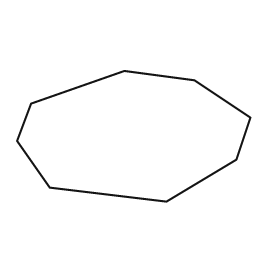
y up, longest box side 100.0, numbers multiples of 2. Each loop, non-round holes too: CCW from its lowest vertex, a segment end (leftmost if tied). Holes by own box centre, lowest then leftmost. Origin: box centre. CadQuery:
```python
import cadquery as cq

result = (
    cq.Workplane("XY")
    .moveTo(14.0, -28.0)
    .lineTo(44.0, -10.0)
    .lineTo(50.0, 8.0)
    .lineTo(26.0, 24.0)
    .lineTo(-4.0, 28.0)
    .lineTo(-44.0, 14.0)
    .lineTo(-50.0, -2.0)
    .lineTo(-36.0, -22.0)
    .close()
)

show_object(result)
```